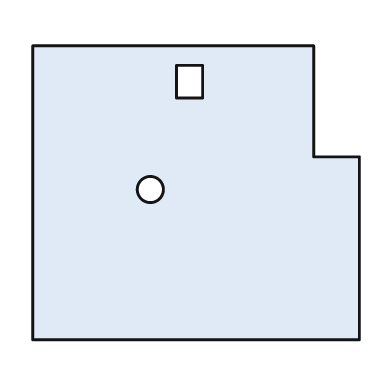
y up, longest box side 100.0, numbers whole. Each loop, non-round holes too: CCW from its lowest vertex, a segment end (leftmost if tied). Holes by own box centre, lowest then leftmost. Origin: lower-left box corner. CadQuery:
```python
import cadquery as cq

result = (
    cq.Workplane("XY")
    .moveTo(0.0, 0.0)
    .lineTo(100.0, 0.0)
    .lineTo(100.0, 56.0)
    .lineTo(86.0, 56.0)
    .lineTo(86.0, 90.0)
    .lineTo(0.0, 90.0)
    .close()
    .moveTo(36.0, 46.0)
    .circle(4.0)
    .moveTo(44.0, 74.0)
    .lineTo(52.0, 74.0)
    .lineTo(52.0, 84.0)
    .lineTo(44.0, 84.0)
    .close()
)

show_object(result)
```